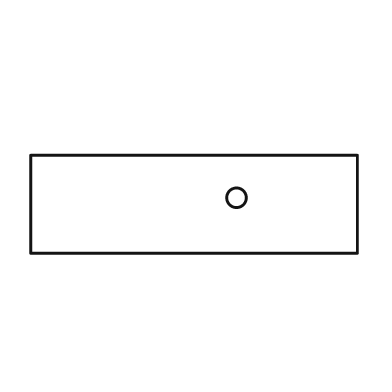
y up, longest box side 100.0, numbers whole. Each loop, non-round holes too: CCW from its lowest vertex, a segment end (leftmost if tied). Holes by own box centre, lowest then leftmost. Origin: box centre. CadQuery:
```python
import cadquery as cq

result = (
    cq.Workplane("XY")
    .moveTo(-50.0, -15.0)
    .lineTo(50.0, -15.0)
    .lineTo(50.0, 15.0)
    .lineTo(-50.0, 15.0)
    .close()
    .moveTo(13.0, 2.0)
    .circle(3.0)
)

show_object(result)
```